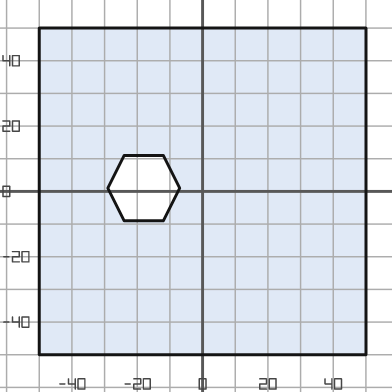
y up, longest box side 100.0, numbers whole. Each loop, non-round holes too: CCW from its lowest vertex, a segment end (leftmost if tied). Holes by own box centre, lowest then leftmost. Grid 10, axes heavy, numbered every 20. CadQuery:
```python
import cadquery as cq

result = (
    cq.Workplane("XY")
    .moveTo(-50.0, -50.0)
    .lineTo(50.0, -50.0)
    .lineTo(50.0, 50.0)
    .lineTo(-50.0, 50.0)
    .close()
    .moveTo(-24.0, -9.0)
    .lineTo(-12.0, -9.0)
    .lineTo(-7.0, 1.0)
    .lineTo(-12.0, 11.0)
    .lineTo(-24.0, 11.0)
    .lineTo(-29.0, 1.0)
    .close()
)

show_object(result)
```